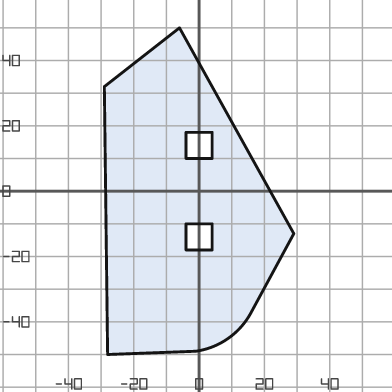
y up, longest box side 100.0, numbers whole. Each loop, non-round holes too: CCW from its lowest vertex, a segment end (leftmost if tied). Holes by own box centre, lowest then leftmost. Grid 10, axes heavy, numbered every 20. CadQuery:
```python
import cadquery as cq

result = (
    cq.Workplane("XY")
    .moveTo(-28.0, -50.0)
    .lineTo(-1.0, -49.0)
    .threePointArc((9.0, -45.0), (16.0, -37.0))
    .lineTo(29.0, -13.0)
    .lineTo(-6.0, 50.0)
    .lineTo(-29.0, 32.0)
    .close()
    .moveTo(-4.0, -18.0)
    .lineTo(4.0, -18.0)
    .lineTo(4.0, -10.0)
    .lineTo(-4.0, -10.0)
    .close()
    .moveTo(-4.0, 10.0)
    .lineTo(4.0, 10.0)
    .lineTo(4.0, 18.0)
    .lineTo(-4.0, 18.0)
    .close()
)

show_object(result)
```